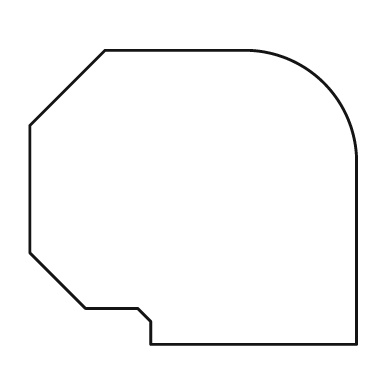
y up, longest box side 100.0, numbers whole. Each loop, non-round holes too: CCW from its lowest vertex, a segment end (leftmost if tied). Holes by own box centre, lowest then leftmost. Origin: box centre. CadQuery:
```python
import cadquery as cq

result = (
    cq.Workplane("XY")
    .moveTo(-13.0, -45.0)
    .lineTo(50.0, -45.0)
    .lineTo(50.0, 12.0)
    .threePointArc((40.0, 35.0), (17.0, 45.0))
    .lineTo(-27.0, 45.0)
    .lineTo(-50.0, 22.0)
    .lineTo(-50.0, -17.0)
    .lineTo(-33.0, -34.0)
    .lineTo(-17.0, -34.0)
    .lineTo(-13.0, -38.0)
    .close()
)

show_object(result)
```